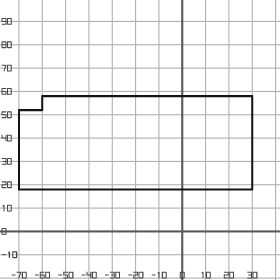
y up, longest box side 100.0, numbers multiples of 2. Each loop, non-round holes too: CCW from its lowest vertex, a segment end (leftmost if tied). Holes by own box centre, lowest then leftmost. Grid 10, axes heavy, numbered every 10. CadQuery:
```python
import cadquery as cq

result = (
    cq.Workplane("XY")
    .moveTo(-70.0, 18.0)
    .lineTo(30.0, 18.0)
    .lineTo(30.0, 58.0)
    .lineTo(-60.0, 58.0)
    .lineTo(-60.0, 52.0)
    .lineTo(-70.0, 52.0)
    .close()
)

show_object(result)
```